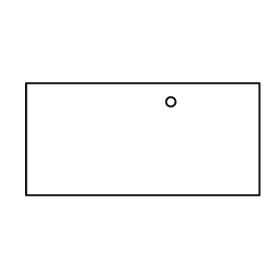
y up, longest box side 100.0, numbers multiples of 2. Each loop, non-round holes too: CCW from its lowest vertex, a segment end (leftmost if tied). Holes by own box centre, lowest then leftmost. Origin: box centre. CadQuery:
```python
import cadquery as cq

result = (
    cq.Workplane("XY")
    .moveTo(-50.0, -24.0)
    .lineTo(50.0, -24.0)
    .lineTo(50.0, 24.0)
    .lineTo(-50.0, 24.0)
    .close()
    .moveTo(12.0, 16.0)
    .circle(2.0)
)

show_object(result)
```